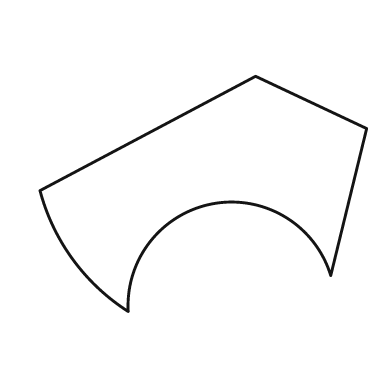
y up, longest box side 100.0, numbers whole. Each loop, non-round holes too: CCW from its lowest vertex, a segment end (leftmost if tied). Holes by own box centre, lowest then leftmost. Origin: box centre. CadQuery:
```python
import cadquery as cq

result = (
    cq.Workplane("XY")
    .moveTo(-23.0, -36.0)
    .threePointArc((3.0, -3.0), (39.0, -25.0))
    .lineTo(50.0, 20.0)
    .lineTo(16.0, 36.0)
    .lineTo(-50.0, 1.0)
    .threePointArc((-40.0, -20.0), (-23.0, -36.0))
    .close()
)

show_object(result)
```